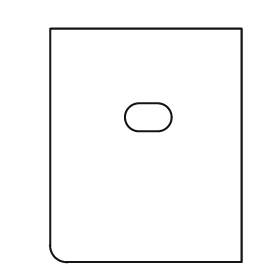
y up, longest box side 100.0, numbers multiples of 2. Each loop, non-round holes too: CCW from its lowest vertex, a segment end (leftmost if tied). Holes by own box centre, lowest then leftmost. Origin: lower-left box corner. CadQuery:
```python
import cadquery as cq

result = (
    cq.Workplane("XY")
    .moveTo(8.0, 0.0)
    .lineTo(82.0, 0.0)
    .lineTo(82.0, 100.0)
    .lineTo(0.0, 100.0)
    .lineTo(0.0, 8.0)
    .threePointArc((2.0, 2.0), (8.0, 0.0))
    .close()
    .moveTo(38.0, 56.0)
    .lineTo(46.0, 56.0)
    .threePointArc((52.0, 62.0), (46.0, 68.0))
    .lineTo(38.0, 68.0)
    .threePointArc((32.0, 62.0), (38.0, 56.0))
    .close()
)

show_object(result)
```